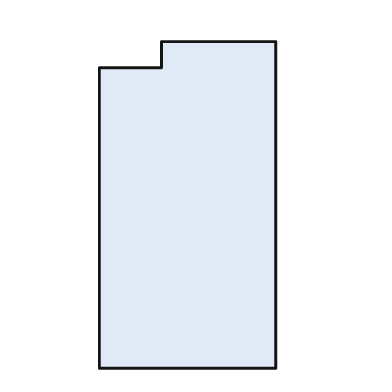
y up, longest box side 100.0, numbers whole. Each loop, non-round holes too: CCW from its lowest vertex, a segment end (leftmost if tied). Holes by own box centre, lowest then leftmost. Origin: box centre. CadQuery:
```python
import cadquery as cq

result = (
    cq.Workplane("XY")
    .moveTo(-27.0, -50.0)
    .lineTo(27.0, -50.0)
    .lineTo(27.0, 50.0)
    .lineTo(-8.0, 50.0)
    .lineTo(-8.0, 42.0)
    .lineTo(-27.0, 42.0)
    .close()
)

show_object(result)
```